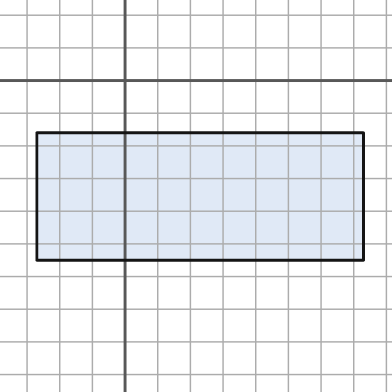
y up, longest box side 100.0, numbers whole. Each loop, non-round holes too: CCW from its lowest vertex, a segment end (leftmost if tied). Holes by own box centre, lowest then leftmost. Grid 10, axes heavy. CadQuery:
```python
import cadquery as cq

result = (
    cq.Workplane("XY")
    .moveTo(-27.0, -55.0)
    .lineTo(73.0, -55.0)
    .lineTo(73.0, -16.0)
    .lineTo(-27.0, -16.0)
    .close()
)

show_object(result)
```